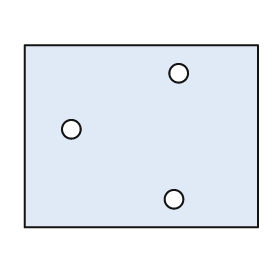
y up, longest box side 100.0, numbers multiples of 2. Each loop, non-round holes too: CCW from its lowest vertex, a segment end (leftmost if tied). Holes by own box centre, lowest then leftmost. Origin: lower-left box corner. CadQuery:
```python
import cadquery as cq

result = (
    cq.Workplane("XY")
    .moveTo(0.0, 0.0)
    .lineTo(100.0, 0.0)
    .lineTo(100.0, 78.0)
    .lineTo(0.0, 78.0)
    .close()
    .moveTo(64.0, 12.0)
    .circle(4.0)
    .moveTo(20.0, 42.0)
    .circle(4.0)
    .moveTo(66.0, 66.0)
    .circle(4.0)
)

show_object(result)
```